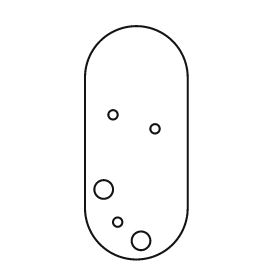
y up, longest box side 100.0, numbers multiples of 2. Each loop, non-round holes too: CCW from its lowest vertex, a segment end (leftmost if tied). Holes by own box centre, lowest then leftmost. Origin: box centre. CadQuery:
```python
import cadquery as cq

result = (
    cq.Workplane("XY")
    .moveTo(-22.0, -28.0)
    .threePointArc((0.0, -50.0), (22.0, -28.0))
    .lineTo(22.0, 28.0)
    .threePointArc((0.0, 50.0), (-22.0, 28.0))
    .close()
    .moveTo(2.0, -42.0)
    .circle(4.0)
    .moveTo(-8.0, -34.0)
    .circle(2.0)
    .moveTo(-14.0, -20.0)
    .circle(4.0)
    .moveTo(8.0, 6.0)
    .circle(2.0)
    .moveTo(-10.0, 12.0)
    .circle(2.0)
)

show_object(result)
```